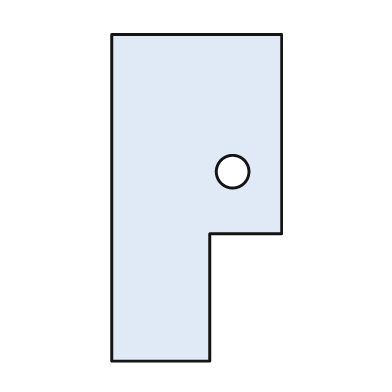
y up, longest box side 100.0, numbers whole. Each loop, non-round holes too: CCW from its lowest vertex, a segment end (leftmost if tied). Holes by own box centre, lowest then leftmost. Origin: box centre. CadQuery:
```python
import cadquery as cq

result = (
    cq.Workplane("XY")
    .moveTo(-26.0, -50.0)
    .lineTo(4.0, -50.0)
    .lineTo(4.0, -11.0)
    .lineTo(26.0, -11.0)
    .lineTo(26.0, 50.0)
    .lineTo(-26.0, 50.0)
    .close()
    .moveTo(11.0, 8.0)
    .circle(5.0)
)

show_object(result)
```